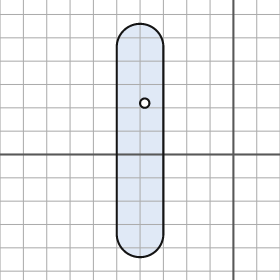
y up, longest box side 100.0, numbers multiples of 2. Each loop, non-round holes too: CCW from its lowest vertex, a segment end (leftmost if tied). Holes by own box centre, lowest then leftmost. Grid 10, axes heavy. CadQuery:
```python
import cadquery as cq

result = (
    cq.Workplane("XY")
    .moveTo(-50.0, -34.0)
    .threePointArc((-40.0, -44.0), (-30.0, -34.0))
    .lineTo(-30.0, 46.0)
    .threePointArc((-40.0, 56.0), (-50.0, 46.0))
    .close()
    .moveTo(-38.0, 22.0)
    .circle(2.0)
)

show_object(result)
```